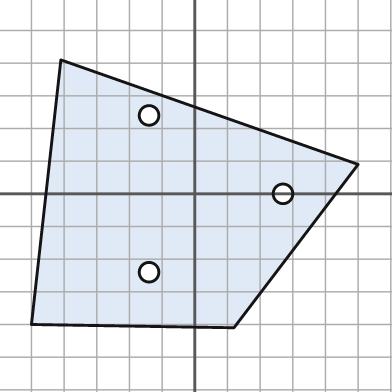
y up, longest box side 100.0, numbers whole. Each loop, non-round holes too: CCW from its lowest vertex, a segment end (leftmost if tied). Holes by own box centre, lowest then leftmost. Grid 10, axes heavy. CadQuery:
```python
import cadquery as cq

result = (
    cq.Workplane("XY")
    .moveTo(12.0, -41.0)
    .lineTo(50.0, 9.0)
    .lineTo(-41.0, 41.0)
    .lineTo(-50.0, -40.0)
    .close()
    .moveTo(-14.0, -24.0)
    .circle(3.0)
    .moveTo(27.0, 0.0)
    .circle(3.0)
    .moveTo(-14.0, 24.0)
    .circle(3.0)
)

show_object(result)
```